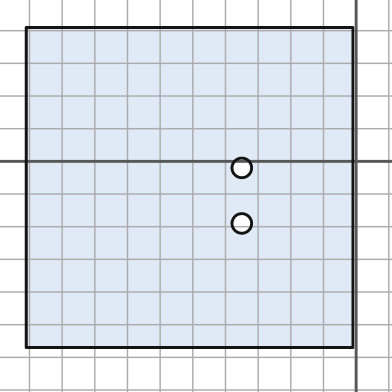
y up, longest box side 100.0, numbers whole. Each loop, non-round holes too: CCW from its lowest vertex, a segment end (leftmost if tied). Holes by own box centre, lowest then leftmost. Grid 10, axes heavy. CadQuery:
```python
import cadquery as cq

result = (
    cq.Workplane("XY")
    .moveTo(-101.0, -57.0)
    .lineTo(-1.0, -57.0)
    .lineTo(-1.0, 41.0)
    .lineTo(-101.0, 41.0)
    .close()
    .moveTo(-35.0, -19.0)
    .circle(3.0)
    .moveTo(-35.0, -2.0)
    .circle(3.0)
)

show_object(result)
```